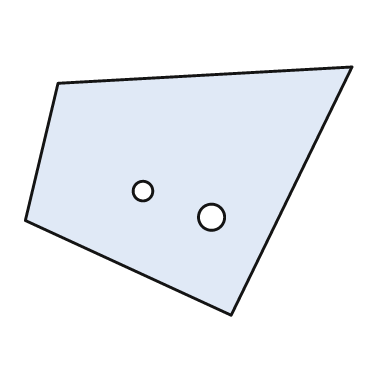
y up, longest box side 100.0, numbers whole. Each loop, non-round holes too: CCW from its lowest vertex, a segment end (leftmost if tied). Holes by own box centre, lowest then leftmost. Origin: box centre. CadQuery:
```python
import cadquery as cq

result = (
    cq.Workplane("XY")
    .moveTo(13.0, -38.0)
    .lineTo(50.0, 38.0)
    .lineTo(-40.0, 33.0)
    .lineTo(-50.0, -9.0)
    .close()
    .moveTo(7.0, -8.0)
    .circle(4.0)
    .moveTo(-14.0, 0.0)
    .circle(3.0)
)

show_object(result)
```